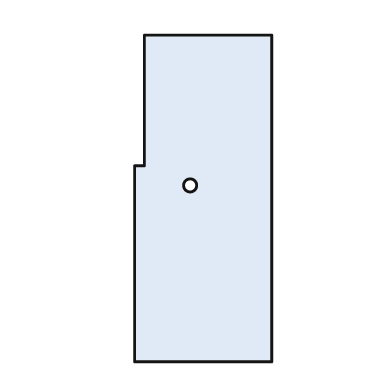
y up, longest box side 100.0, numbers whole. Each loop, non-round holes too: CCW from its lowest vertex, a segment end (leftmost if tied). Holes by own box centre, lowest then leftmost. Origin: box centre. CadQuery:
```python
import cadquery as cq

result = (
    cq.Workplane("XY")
    .moveTo(-21.0, -50.0)
    .lineTo(21.0, -50.0)
    .lineTo(21.0, 50.0)
    .lineTo(-18.0, 50.0)
    .lineTo(-18.0, 10.0)
    .lineTo(-21.0, 10.0)
    .close()
    .moveTo(-4.0, 4.0)
    .circle(2.0)
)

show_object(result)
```